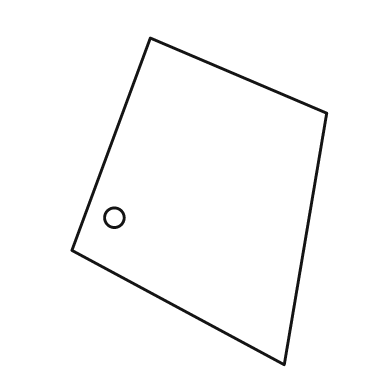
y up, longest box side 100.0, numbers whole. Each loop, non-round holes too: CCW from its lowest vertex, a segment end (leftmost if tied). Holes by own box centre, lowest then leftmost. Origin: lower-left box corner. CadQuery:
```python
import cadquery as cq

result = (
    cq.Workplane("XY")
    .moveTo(65.0, 0.0)
    .lineTo(78.0, 77.0)
    .lineTo(24.0, 100.0)
    .lineTo(0.0, 35.0)
    .close()
    .moveTo(13.0, 45.0)
    .circle(3.0)
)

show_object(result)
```